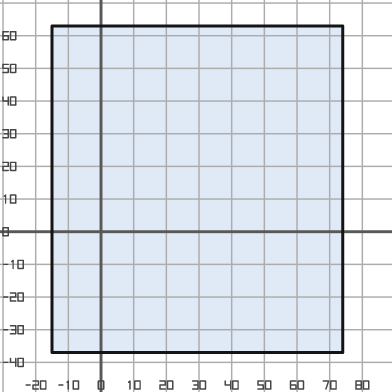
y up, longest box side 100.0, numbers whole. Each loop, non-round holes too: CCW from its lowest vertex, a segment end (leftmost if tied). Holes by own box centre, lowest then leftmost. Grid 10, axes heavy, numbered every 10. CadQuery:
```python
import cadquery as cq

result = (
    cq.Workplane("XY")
    .moveTo(-15.0, -37.0)
    .lineTo(74.0, -37.0)
    .lineTo(74.0, 63.0)
    .lineTo(-15.0, 63.0)
    .close()
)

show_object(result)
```